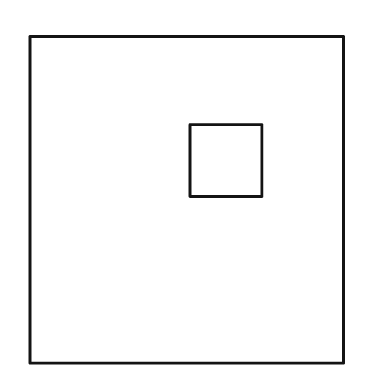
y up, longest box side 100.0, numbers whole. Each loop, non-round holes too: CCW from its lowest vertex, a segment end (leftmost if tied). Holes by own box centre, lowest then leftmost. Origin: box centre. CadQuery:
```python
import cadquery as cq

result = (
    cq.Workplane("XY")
    .moveTo(-48.0, -50.0)
    .lineTo(48.0, -50.0)
    .lineTo(48.0, 50.0)
    .lineTo(-48.0, 50.0)
    .close()
    .moveTo(1.0, 1.0)
    .lineTo(23.0, 1.0)
    .lineTo(23.0, 23.0)
    .lineTo(1.0, 23.0)
    .close()
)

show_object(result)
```